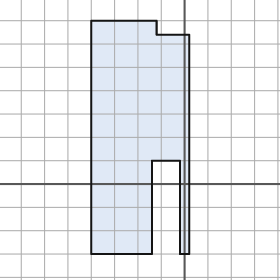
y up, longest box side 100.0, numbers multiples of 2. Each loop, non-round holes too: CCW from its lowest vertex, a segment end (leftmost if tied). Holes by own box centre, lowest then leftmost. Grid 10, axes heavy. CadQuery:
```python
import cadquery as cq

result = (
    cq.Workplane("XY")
    .moveTo(-40.0, -30.0)
    .lineTo(-14.0, -30.0)
    .lineTo(-14.0, 10.0)
    .lineTo(-2.0, 10.0)
    .lineTo(-2.0, -30.0)
    .lineTo(2.0, -30.0)
    .lineTo(2.0, 64.0)
    .lineTo(-12.0, 64.0)
    .lineTo(-12.0, 70.0)
    .lineTo(-40.0, 70.0)
    .close()
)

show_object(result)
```